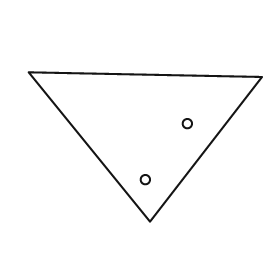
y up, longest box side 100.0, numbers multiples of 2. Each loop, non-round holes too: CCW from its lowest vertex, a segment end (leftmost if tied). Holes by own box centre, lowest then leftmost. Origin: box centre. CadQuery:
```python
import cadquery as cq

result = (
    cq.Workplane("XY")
    .moveTo(2.0, -32.0)
    .lineTo(50.0, 30.0)
    .lineTo(-50.0, 32.0)
    .close()
    .moveTo(0.0, -14.0)
    .circle(2.0)
    .moveTo(18.0, 10.0)
    .circle(2.0)
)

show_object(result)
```